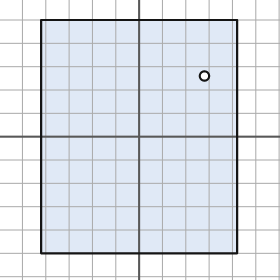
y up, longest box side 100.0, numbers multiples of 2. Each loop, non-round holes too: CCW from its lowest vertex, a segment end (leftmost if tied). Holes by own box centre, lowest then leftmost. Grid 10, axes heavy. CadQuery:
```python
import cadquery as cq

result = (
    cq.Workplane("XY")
    .moveTo(-42.0, -50.0)
    .lineTo(42.0, -50.0)
    .lineTo(42.0, 50.0)
    .lineTo(-42.0, 50.0)
    .close()
    .moveTo(28.0, 26.0)
    .circle(2.0)
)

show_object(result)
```